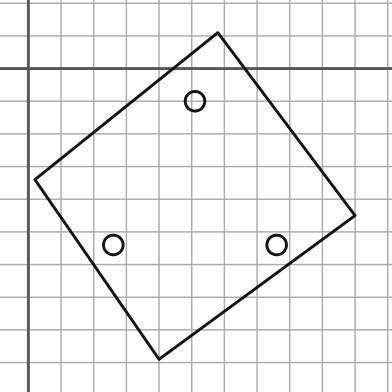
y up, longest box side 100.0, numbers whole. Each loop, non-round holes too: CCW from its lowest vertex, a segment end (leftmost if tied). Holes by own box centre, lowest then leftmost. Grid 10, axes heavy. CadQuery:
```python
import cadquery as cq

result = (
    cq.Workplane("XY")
    .moveTo(40.0, -89.0)
    .lineTo(100.0, -45.0)
    .lineTo(58.0, 11.0)
    .lineTo(2.0, -34.0)
    .close()
    .moveTo(26.0, -54.0)
    .circle(3.0)
    .moveTo(76.0, -54.0)
    .circle(3.0)
    .moveTo(51.0, -10.0)
    .circle(3.0)
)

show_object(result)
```